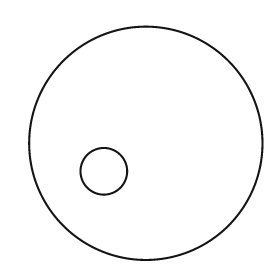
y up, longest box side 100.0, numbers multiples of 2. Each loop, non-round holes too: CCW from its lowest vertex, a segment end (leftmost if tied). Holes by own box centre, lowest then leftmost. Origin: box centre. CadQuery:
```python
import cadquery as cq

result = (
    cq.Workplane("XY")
    .moveTo(0.0, 0.0)
    .circle(50.0)
    .moveTo(-18.0, -12.0)
    .circle(10.0)
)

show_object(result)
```